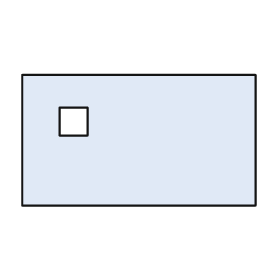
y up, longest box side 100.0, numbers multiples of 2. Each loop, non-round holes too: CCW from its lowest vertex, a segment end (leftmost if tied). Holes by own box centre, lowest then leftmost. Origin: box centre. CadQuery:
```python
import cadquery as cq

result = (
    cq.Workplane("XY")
    .moveTo(-50.0, -28.0)
    .lineTo(50.0, -28.0)
    .lineTo(50.0, 28.0)
    .lineTo(-50.0, 28.0)
    .close()
    .moveTo(-34.0, 2.0)
    .lineTo(-22.0, 2.0)
    .lineTo(-22.0, 14.0)
    .lineTo(-34.0, 14.0)
    .close()
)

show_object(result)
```